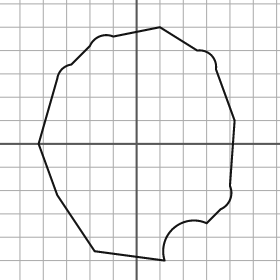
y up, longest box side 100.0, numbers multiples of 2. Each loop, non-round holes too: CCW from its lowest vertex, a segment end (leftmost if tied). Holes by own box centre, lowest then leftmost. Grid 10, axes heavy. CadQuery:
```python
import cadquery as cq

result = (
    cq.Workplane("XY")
    .moveTo(12.0, -50.0)
    .threePointArc((16.0, -36.0), (30.0, -34.0))
    .lineTo(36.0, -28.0)
    .threePointArc((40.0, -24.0), (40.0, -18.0))
    .lineTo(42.0, 10.0)
    .lineTo(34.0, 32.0)
    .threePointArc((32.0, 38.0), (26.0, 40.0))
    .lineTo(10.0, 50.0)
    .lineTo(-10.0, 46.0)
    .threePointArc((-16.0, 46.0), (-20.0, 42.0))
    .lineTo(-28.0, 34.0)
    .threePointArc((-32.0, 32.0), (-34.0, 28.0))
    .lineTo(-42.0, 0.0)
    .lineTo(-34.0, -22.0)
    .lineTo(-18.0, -46.0)
    .close()
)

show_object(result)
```